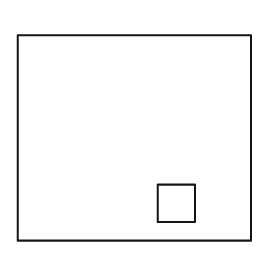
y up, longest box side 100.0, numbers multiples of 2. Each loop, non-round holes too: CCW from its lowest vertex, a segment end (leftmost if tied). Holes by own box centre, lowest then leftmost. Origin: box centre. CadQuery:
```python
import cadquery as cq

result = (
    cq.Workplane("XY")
    .moveTo(-50.0, -44.0)
    .lineTo(50.0, -44.0)
    .lineTo(50.0, 44.0)
    .lineTo(-50.0, 44.0)
    .close()
    .moveTo(10.0, -36.0)
    .lineTo(26.0, -36.0)
    .lineTo(26.0, -20.0)
    .lineTo(10.0, -20.0)
    .close()
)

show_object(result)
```